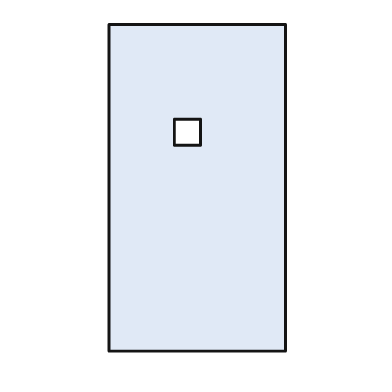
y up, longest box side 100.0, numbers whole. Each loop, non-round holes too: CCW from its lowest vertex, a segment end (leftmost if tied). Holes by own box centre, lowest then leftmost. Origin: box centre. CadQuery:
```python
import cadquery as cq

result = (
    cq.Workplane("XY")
    .moveTo(-27.0, -50.0)
    .lineTo(27.0, -50.0)
    .lineTo(27.0, 50.0)
    .lineTo(-27.0, 50.0)
    .close()
    .moveTo(-7.0, 13.0)
    .lineTo(1.0, 13.0)
    .lineTo(1.0, 21.0)
    .lineTo(-7.0, 21.0)
    .close()
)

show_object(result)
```